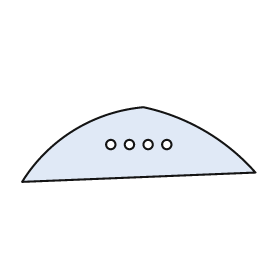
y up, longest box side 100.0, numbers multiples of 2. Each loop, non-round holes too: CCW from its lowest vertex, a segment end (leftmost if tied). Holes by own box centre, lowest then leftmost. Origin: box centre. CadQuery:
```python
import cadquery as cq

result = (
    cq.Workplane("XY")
    .moveTo(-50.0, -16.0)
    .lineTo(50.0, -12.0)
    .threePointArc((28.0, 6.0), (2.0, 16.0))
    .threePointArc((-28.0, 6.0), (-50.0, -16.0))
    .close()
    .moveTo(-12.0, 0.0)
    .circle(2.0)
    .moveTo(-4.0, 0.0)
    .circle(2.0)
    .moveTo(4.0, 0.0)
    .circle(2.0)
    .moveTo(12.0, 0.0)
    .circle(2.0)
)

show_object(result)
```